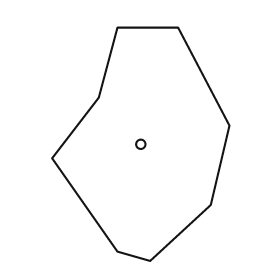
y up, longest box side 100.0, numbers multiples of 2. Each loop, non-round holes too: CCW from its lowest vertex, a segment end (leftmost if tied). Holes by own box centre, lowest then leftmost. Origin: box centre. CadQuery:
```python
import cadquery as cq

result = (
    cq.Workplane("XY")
    .moveTo(4.0, -50.0)
    .lineTo(30.0, -26.0)
    .lineTo(38.0, 8.0)
    .lineTo(16.0, 50.0)
    .lineTo(-10.0, 50.0)
    .lineTo(-18.0, 20.0)
    .lineTo(-38.0, -6.0)
    .lineTo(-10.0, -46.0)
    .close()
    .moveTo(0.0, 0.0)
    .circle(2.0)
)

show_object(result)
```